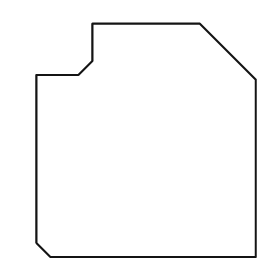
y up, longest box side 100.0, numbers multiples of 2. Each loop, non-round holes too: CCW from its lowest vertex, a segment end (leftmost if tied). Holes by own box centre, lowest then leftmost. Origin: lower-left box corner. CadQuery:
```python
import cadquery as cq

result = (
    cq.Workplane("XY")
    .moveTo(6.0, 0.0)
    .lineTo(94.0, 0.0)
    .lineTo(94.0, 76.0)
    .lineTo(70.0, 100.0)
    .lineTo(24.0, 100.0)
    .lineTo(24.0, 84.0)
    .lineTo(18.0, 78.0)
    .lineTo(0.0, 78.0)
    .lineTo(0.0, 6.0)
    .close()
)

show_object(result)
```